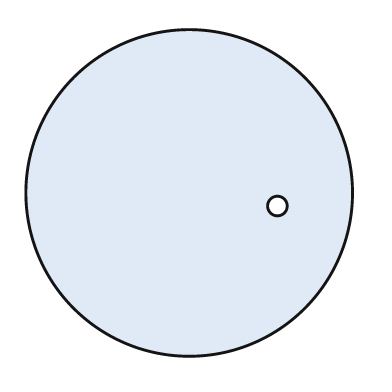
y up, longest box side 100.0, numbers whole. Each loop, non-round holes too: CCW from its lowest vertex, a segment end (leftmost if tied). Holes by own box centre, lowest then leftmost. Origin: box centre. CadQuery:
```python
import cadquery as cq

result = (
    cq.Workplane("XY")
    .moveTo(0.0, 0.0)
    .circle(50.0)
    .moveTo(27.0, -4.0)
    .circle(3.0)
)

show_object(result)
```